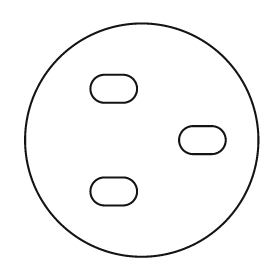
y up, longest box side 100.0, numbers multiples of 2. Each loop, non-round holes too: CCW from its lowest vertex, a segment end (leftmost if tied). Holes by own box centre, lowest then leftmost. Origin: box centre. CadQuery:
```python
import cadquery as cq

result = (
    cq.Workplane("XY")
    .moveTo(0.0, 0.0)
    .circle(50.0)
    .moveTo(-16.0, -28.0)
    .lineTo(-8.0, -28.0)
    .threePointArc((-2.0, -22.0), (-8.0, -16.0))
    .lineTo(-16.0, -16.0)
    .threePointArc((-22.0, -22.0), (-16.0, -28.0))
    .close()
    .moveTo(22.0, -6.0)
    .lineTo(30.0, -6.0)
    .threePointArc((36.0, 0.0), (30.0, 6.0))
    .lineTo(22.0, 6.0)
    .threePointArc((16.0, 0.0), (22.0, -6.0))
    .close()
    .moveTo(-16.0, 16.0)
    .lineTo(-8.0, 16.0)
    .threePointArc((-2.0, 22.0), (-8.0, 28.0))
    .lineTo(-16.0, 28.0)
    .threePointArc((-22.0, 22.0), (-16.0, 16.0))
    .close()
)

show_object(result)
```